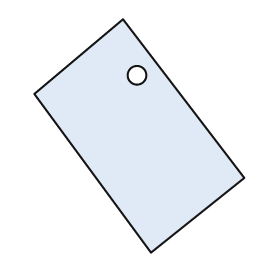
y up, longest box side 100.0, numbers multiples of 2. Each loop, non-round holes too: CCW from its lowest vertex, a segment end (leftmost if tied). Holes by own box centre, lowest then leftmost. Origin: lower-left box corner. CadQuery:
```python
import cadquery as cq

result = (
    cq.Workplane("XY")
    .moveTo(50.0, 0.0)
    .lineTo(90.0, 32.0)
    .lineTo(38.0, 100.0)
    .lineTo(0.0, 68.0)
    .close()
    .moveTo(44.0, 76.0)
    .circle(4.0)
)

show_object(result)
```